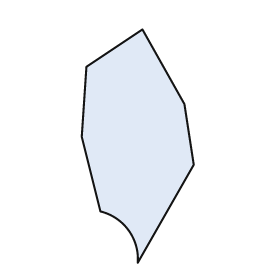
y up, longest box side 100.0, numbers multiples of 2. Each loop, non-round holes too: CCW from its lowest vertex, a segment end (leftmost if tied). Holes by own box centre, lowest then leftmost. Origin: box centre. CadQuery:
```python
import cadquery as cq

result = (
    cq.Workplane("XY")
    .moveTo(0.0, -50.0)
    .lineTo(24.0, -8.0)
    .lineTo(20.0, 18.0)
    .lineTo(2.0, 50.0)
    .lineTo(-22.0, 34.0)
    .lineTo(-24.0, 4.0)
    .lineTo(-16.0, -28.0)
    .threePointArc((-4.0, -36.0), (0.0, -50.0))
    .close()
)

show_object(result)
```